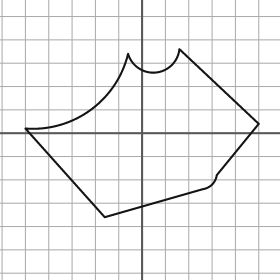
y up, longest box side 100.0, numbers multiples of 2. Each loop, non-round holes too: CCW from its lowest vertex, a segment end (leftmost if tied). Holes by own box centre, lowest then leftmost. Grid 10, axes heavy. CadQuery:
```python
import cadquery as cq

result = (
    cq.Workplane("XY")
    .moveTo(-16.0, -36.0)
    .lineTo(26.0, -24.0)
    .threePointArc((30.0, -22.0), (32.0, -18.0))
    .lineTo(50.0, 4.0)
    .lineTo(16.0, 36.0)
    .threePointArc((6.0, 26.0), (-6.0, 34.0))
    .threePointArc((-22.0, 10.0), (-50.0, 2.0))
    .close()
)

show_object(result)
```